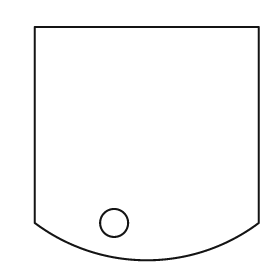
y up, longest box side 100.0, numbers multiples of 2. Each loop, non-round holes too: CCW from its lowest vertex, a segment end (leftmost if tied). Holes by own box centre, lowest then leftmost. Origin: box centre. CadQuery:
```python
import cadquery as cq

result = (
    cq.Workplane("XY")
    .moveTo(-48.0, -34.0)
    .threePointArc((0.0, -50.0), (48.0, -34.0))
    .lineTo(48.0, 50.0)
    .lineTo(-48.0, 50.0)
    .close()
    .moveTo(-14.0, -34.0)
    .circle(6.0)
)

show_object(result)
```